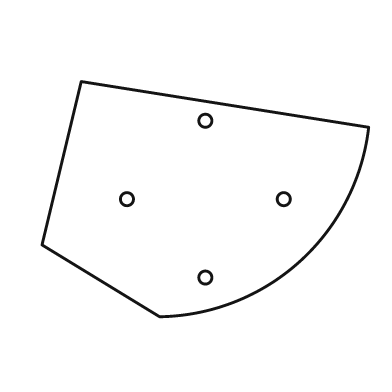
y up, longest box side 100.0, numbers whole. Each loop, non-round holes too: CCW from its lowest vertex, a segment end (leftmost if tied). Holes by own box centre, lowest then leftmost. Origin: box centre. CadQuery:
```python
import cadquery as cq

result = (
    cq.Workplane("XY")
    .moveTo(-14.0, -36.0)
    .threePointArc((29.0, -19.0), (50.0, 22.0))
    .lineTo(-38.0, 36.0)
    .lineTo(-50.0, -14.0)
    .close()
    .moveTo(0.0, -24.0)
    .circle(2.0)
    .moveTo(-24.0, 0.0)
    .circle(2.0)
    .moveTo(24.0, 0.0)
    .circle(2.0)
    .moveTo(0.0, 24.0)
    .circle(2.0)
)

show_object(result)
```